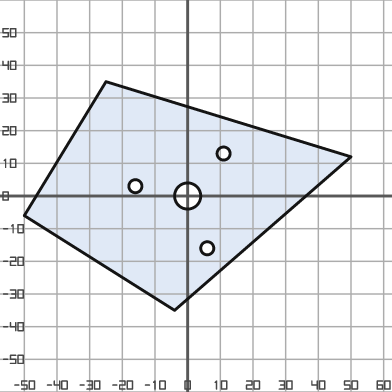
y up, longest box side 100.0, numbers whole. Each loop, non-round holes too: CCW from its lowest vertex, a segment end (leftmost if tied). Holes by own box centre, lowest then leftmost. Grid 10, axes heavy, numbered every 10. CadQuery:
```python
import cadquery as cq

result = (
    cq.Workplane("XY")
    .moveTo(-4.0, -35.0)
    .lineTo(50.0, 12.0)
    .lineTo(-25.0, 35.0)
    .lineTo(-50.0, -6.0)
    .close()
    .moveTo(6.0, -16.0)
    .circle(2.0)
    .moveTo(0.0, 0.0)
    .circle(4.0)
    .moveTo(-16.0, 3.0)
    .circle(2.0)
    .moveTo(11.0, 13.0)
    .circle(2.0)
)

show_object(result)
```